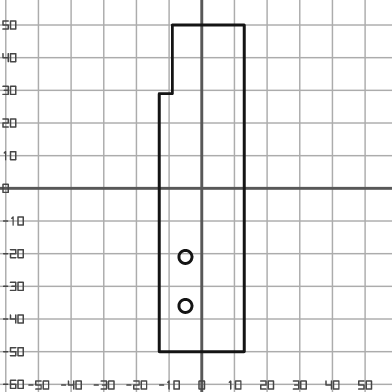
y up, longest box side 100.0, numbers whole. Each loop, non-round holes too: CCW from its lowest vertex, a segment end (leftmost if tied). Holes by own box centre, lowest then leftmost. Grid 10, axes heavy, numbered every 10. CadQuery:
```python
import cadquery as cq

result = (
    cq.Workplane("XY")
    .moveTo(-13.0, -50.0)
    .lineTo(13.0, -50.0)
    .lineTo(13.0, 50.0)
    .lineTo(-9.0, 50.0)
    .lineTo(-9.0, 29.0)
    .lineTo(-13.0, 29.0)
    .close()
    .moveTo(-5.0, -36.0)
    .circle(2.0)
    .moveTo(-5.0, -21.0)
    .circle(2.0)
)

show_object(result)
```